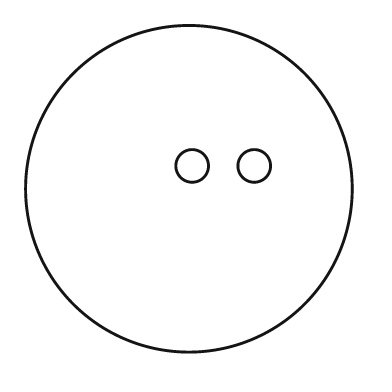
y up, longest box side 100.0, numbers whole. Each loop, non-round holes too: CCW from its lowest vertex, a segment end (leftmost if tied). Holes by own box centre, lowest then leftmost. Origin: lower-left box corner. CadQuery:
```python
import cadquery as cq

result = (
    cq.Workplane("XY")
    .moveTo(50.0, 50.0)
    .circle(50.0)
    .moveTo(51.0, 57.0)
    .circle(5.0)
    .moveTo(70.0, 57.0)
    .circle(5.0)
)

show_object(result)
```